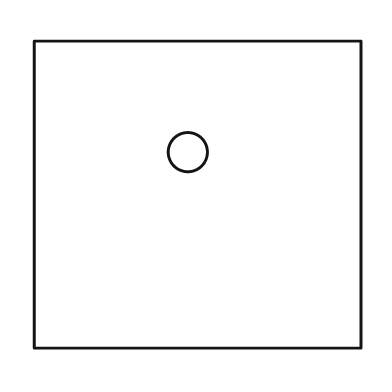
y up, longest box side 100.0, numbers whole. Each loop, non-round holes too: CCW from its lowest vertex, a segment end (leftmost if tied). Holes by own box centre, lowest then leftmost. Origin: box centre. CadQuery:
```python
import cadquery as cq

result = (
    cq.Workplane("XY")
    .moveTo(-50.0, -47.0)
    .lineTo(50.0, -47.0)
    .lineTo(50.0, 47.0)
    .lineTo(-50.0, 47.0)
    .close()
    .moveTo(-3.0, 13.0)
    .circle(6.0)
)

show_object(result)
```